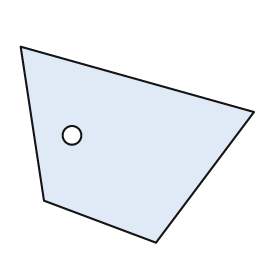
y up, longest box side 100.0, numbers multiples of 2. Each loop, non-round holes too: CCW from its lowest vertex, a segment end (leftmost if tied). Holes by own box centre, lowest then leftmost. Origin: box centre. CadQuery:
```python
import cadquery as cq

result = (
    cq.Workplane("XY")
    .moveTo(8.0, -42.0)
    .lineTo(50.0, 14.0)
    .lineTo(-50.0, 42.0)
    .lineTo(-40.0, -24.0)
    .close()
    .moveTo(-28.0, 4.0)
    .circle(4.0)
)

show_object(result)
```